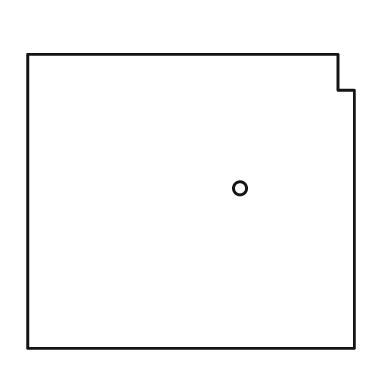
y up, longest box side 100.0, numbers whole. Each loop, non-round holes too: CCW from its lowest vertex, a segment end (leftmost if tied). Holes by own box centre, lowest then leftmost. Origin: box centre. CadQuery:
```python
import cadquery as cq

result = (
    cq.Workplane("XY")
    .moveTo(-50.0, -45.0)
    .lineTo(50.0, -45.0)
    .lineTo(50.0, 34.0)
    .lineTo(45.0, 34.0)
    .lineTo(45.0, 45.0)
    .lineTo(-50.0, 45.0)
    .close()
    .moveTo(15.0, 4.0)
    .circle(2.0)
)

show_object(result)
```